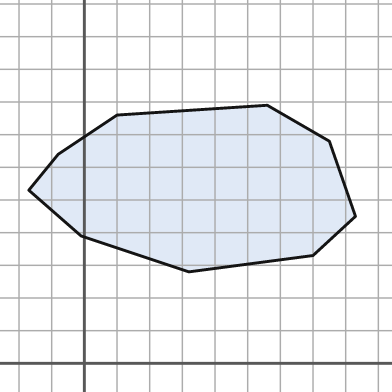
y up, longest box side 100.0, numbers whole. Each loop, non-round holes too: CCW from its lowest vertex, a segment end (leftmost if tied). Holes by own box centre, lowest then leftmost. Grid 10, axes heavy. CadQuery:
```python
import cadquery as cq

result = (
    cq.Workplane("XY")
    .moveTo(32.0, 28.0)
    .lineTo(70.0, 33.0)
    .lineTo(83.0, 45.0)
    .lineTo(75.0, 68.0)
    .lineTo(56.0, 79.0)
    .lineTo(10.0, 76.0)
    .lineTo(-8.0, 64.0)
    .lineTo(-17.0, 53.0)
    .lineTo(-1.0, 39.0)
    .close()
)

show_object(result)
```